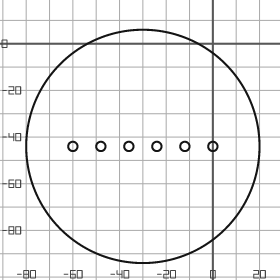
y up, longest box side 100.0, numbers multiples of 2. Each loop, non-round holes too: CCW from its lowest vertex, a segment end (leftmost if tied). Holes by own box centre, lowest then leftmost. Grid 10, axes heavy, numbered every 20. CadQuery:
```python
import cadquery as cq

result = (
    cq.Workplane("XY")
    .moveTo(-30.0, -44.0)
    .circle(50.0)
    .moveTo(-60.0, -44.0)
    .circle(2.0)
    .moveTo(-48.0, -44.0)
    .circle(2.0)
    .moveTo(-36.0, -44.0)
    .circle(2.0)
    .moveTo(-24.0, -44.0)
    .circle(2.0)
    .moveTo(-12.0, -44.0)
    .circle(2.0)
    .moveTo(0.0, -44.0)
    .circle(2.0)
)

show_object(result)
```